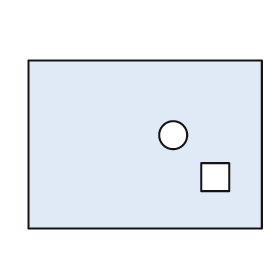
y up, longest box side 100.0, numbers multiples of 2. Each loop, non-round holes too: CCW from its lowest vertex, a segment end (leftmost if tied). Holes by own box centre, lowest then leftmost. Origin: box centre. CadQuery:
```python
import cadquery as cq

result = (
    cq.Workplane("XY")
    .moveTo(-50.0, -36.0)
    .lineTo(50.0, -36.0)
    .lineTo(50.0, 36.0)
    .lineTo(-50.0, 36.0)
    .close()
    .moveTo(24.0, -20.0)
    .lineTo(36.0, -20.0)
    .lineTo(36.0, -8.0)
    .lineTo(24.0, -8.0)
    .close()
    .moveTo(12.0, 4.0)
    .circle(6.0)
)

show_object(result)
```